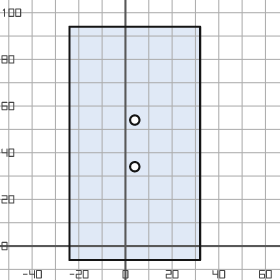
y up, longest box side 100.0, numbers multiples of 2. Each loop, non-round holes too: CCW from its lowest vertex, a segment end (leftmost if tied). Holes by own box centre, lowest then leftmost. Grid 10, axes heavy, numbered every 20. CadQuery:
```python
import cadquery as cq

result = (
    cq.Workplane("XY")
    .moveTo(-24.0, -6.0)
    .lineTo(32.0, -6.0)
    .lineTo(32.0, 94.0)
    .lineTo(-24.0, 94.0)
    .close()
    .moveTo(4.0, 34.0)
    .circle(2.0)
    .moveTo(4.0, 54.0)
    .circle(2.0)
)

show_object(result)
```